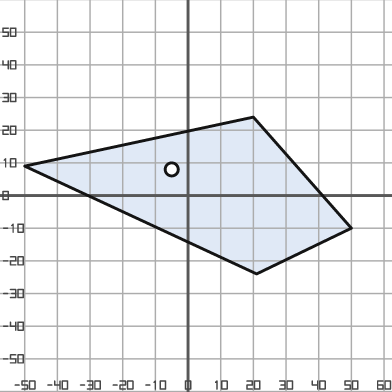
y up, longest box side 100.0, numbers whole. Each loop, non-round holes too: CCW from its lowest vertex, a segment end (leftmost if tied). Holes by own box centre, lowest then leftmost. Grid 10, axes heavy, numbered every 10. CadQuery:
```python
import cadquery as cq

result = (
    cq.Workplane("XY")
    .moveTo(21.0, -24.0)
    .lineTo(50.0, -10.0)
    .lineTo(20.0, 24.0)
    .lineTo(-50.0, 9.0)
    .close()
    .moveTo(-5.0, 8.0)
    .circle(2.0)
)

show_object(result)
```